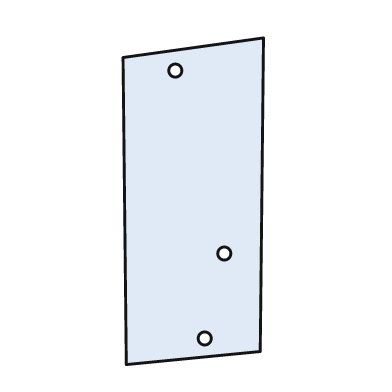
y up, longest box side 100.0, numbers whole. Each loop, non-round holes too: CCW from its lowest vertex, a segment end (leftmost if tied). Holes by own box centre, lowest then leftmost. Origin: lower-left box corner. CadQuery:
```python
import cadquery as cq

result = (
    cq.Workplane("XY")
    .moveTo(1.0, 0.0)
    .lineTo(42.0, 4.0)
    .lineTo(43.0, 100.0)
    .lineTo(0.0, 94.0)
    .close()
    .moveTo(25.0, 8.0)
    .circle(2.0)
    .moveTo(31.0, 34.0)
    .circle(2.0)
    .moveTo(16.0, 90.0)
    .circle(2.0)
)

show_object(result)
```